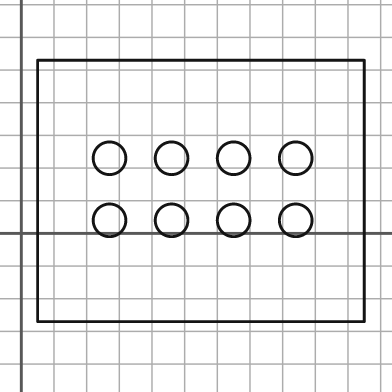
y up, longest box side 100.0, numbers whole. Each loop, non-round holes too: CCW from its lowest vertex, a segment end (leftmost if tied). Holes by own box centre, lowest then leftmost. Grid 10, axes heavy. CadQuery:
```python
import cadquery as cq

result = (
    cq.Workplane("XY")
    .moveTo(5.0, -27.0)
    .lineTo(105.0, -27.0)
    .lineTo(105.0, 53.0)
    .lineTo(5.0, 53.0)
    .close()
    .moveTo(27.0, 4.0)
    .circle(5.0)
    .moveTo(46.0, 4.0)
    .circle(5.0)
    .moveTo(65.0, 4.0)
    .circle(5.0)
    .moveTo(84.0, 4.0)
    .circle(5.0)
    .moveTo(27.0, 23.0)
    .circle(5.0)
    .moveTo(46.0, 23.0)
    .circle(5.0)
    .moveTo(65.0, 23.0)
    .circle(5.0)
    .moveTo(84.0, 23.0)
    .circle(5.0)
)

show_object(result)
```